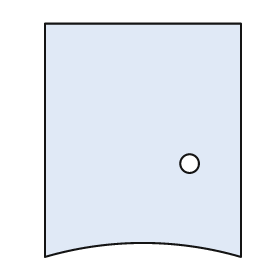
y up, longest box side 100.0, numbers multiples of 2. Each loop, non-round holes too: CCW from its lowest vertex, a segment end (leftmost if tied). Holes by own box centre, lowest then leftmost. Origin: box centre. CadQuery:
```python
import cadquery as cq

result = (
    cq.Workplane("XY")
    .moveTo(-42.0, -50.0)
    .threePointArc((0.0, -44.0), (42.0, -50.0))
    .lineTo(42.0, 50.0)
    .lineTo(-42.0, 50.0)
    .close()
    .moveTo(20.0, -10.0)
    .circle(4.0)
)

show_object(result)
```